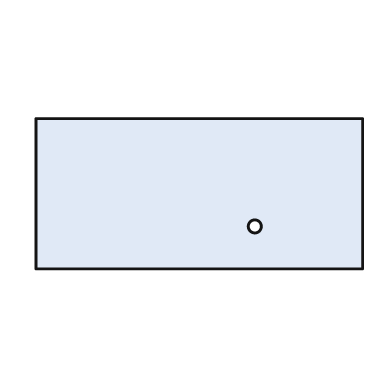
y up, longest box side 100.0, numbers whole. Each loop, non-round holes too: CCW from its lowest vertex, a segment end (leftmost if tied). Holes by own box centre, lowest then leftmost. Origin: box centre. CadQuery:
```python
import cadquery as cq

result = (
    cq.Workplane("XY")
    .moveTo(-50.0, -23.0)
    .lineTo(50.0, -23.0)
    .lineTo(50.0, 23.0)
    .lineTo(-50.0, 23.0)
    .close()
    .moveTo(17.0, -10.0)
    .circle(2.0)
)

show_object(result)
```